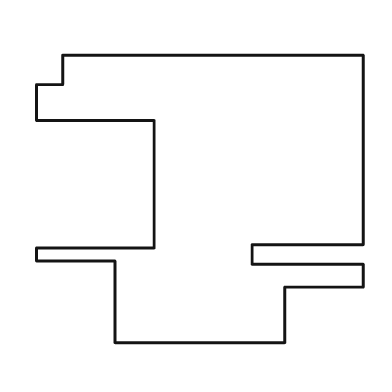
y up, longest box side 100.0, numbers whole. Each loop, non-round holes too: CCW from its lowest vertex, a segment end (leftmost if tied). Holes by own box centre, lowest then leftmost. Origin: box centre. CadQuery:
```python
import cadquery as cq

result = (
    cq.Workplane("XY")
    .moveTo(-26.0, -44.0)
    .lineTo(26.0, -44.0)
    .lineTo(26.0, -27.0)
    .lineTo(50.0, -27.0)
    .lineTo(50.0, -20.0)
    .lineTo(16.0, -20.0)
    .lineTo(16.0, -14.0)
    .lineTo(50.0, -14.0)
    .lineTo(50.0, 44.0)
    .lineTo(-42.0, 44.0)
    .lineTo(-42.0, 35.0)
    .lineTo(-50.0, 35.0)
    .lineTo(-50.0, 24.0)
    .lineTo(-14.0, 24.0)
    .lineTo(-14.0, -15.0)
    .lineTo(-50.0, -15.0)
    .lineTo(-50.0, -19.0)
    .lineTo(-26.0, -19.0)
    .close()
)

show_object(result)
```